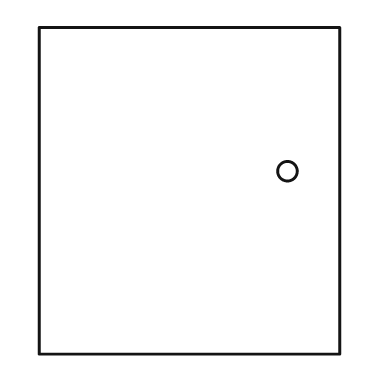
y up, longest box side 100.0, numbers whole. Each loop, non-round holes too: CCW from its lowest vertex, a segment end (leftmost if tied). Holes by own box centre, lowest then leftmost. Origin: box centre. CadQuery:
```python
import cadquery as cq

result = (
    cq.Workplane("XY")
    .moveTo(-46.0, -50.0)
    .lineTo(46.0, -50.0)
    .lineTo(46.0, 50.0)
    .lineTo(-46.0, 50.0)
    .close()
    .moveTo(30.0, 6.0)
    .circle(3.0)
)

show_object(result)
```